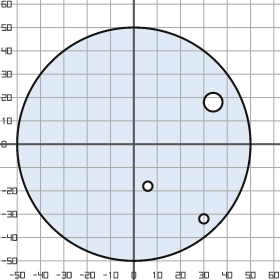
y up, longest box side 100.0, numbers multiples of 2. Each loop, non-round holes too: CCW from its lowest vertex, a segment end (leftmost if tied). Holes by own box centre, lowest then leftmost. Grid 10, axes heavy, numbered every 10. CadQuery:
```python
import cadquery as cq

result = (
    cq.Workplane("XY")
    .moveTo(0.0, 0.0)
    .circle(50.0)
    .moveTo(30.0, -32.0)
    .circle(2.0)
    .moveTo(6.0, -18.0)
    .circle(2.0)
    .moveTo(34.0, 18.0)
    .circle(4.0)
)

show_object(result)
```